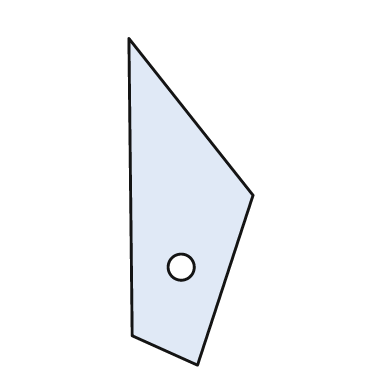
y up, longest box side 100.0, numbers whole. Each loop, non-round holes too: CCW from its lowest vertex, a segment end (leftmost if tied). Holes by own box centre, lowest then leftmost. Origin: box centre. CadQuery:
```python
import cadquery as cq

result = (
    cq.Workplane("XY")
    .moveTo(2.0, -50.0)
    .lineTo(19.0, 2.0)
    .lineTo(-19.0, 50.0)
    .lineTo(-18.0, -41.0)
    .close()
    .moveTo(-3.0, -20.0)
    .circle(4.0)
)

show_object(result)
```